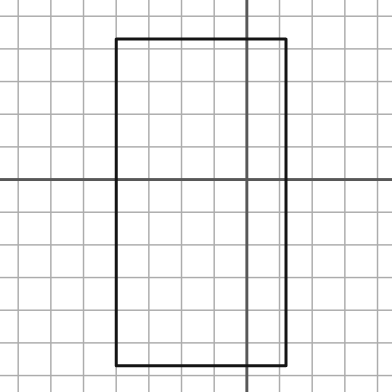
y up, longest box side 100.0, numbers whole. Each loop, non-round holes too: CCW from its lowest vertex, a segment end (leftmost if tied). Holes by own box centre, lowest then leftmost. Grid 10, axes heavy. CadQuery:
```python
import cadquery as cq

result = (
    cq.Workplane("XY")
    .moveTo(-40.0, -57.0)
    .lineTo(12.0, -57.0)
    .lineTo(12.0, 43.0)
    .lineTo(-40.0, 43.0)
    .close()
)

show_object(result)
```